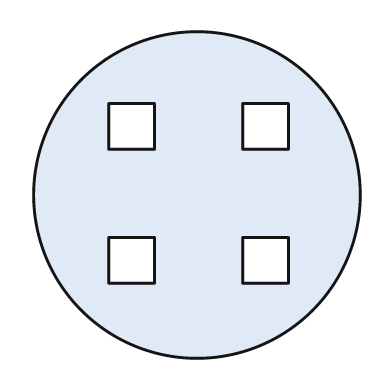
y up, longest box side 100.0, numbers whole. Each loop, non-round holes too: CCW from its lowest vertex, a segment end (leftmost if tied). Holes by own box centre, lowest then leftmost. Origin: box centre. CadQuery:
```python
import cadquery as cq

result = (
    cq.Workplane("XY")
    .moveTo(0.0, 0.0)
    .circle(50.0)
    .moveTo(-27.0, -27.0)
    .lineTo(-13.0, -27.0)
    .lineTo(-13.0, -13.0)
    .lineTo(-27.0, -13.0)
    .close()
    .moveTo(14.0, -27.0)
    .lineTo(28.0, -27.0)
    .lineTo(28.0, -13.0)
    .lineTo(14.0, -13.0)
    .close()
    .moveTo(-27.0, 14.0)
    .lineTo(-13.0, 14.0)
    .lineTo(-13.0, 28.0)
    .lineTo(-27.0, 28.0)
    .close()
    .moveTo(14.0, 14.0)
    .lineTo(28.0, 14.0)
    .lineTo(28.0, 28.0)
    .lineTo(14.0, 28.0)
    .close()
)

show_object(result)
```